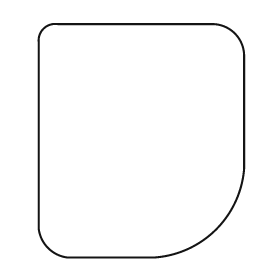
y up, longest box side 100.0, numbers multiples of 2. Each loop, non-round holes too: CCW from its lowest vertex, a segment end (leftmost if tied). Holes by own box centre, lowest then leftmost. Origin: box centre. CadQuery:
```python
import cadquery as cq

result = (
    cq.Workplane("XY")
    .moveTo(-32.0, -50.0)
    .lineTo(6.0, -50.0)
    .threePointArc((32.0, -38.0), (44.0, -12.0))
    .lineTo(44.0, 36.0)
    .threePointArc((40.0, 46.0), (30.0, 50.0))
    .lineTo(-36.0, 50.0)
    .threePointArc((-42.0, 48.0), (-44.0, 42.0))
    .lineTo(-44.0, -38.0)
    .threePointArc((-40.0, -46.0), (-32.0, -50.0))
    .close()
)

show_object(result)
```